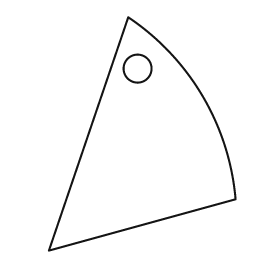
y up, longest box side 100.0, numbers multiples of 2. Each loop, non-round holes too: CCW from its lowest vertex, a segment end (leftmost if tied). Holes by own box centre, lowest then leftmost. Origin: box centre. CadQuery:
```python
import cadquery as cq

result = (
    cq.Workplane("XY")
    .moveTo(-40.0, -50.0)
    .lineTo(40.0, -28.0)
    .threePointArc((26.0, 16.0), (-6.0, 50.0))
    .close()
    .moveTo(-2.0, 28.0)
    .circle(6.0)
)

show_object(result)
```